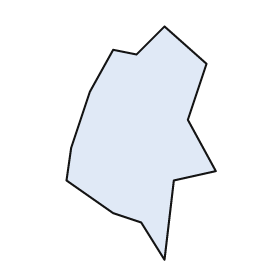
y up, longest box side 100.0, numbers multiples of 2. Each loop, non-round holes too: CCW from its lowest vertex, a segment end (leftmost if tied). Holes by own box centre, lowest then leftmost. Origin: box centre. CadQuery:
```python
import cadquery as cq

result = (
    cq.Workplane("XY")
    .moveTo(10.0, -50.0)
    .lineTo(14.0, -16.0)
    .lineTo(32.0, -12.0)
    .lineTo(20.0, 10.0)
    .lineTo(28.0, 34.0)
    .lineTo(10.0, 50.0)
    .lineTo(-2.0, 38.0)
    .lineTo(-12.0, 40.0)
    .lineTo(-22.0, 22.0)
    .lineTo(-30.0, -2.0)
    .lineTo(-32.0, -16.0)
    .lineTo(-12.0, -30.0)
    .lineTo(0.0, -34.0)
    .close()
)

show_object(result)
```